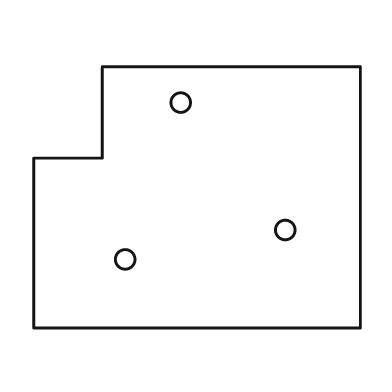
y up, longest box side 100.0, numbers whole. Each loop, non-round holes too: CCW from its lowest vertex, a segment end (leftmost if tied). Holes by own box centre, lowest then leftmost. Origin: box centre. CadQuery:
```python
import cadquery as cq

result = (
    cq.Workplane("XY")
    .moveTo(-50.0, -40.0)
    .lineTo(50.0, -40.0)
    .lineTo(50.0, 40.0)
    .lineTo(-29.0, 40.0)
    .lineTo(-29.0, 12.0)
    .lineTo(-50.0, 12.0)
    .close()
    .moveTo(-22.0, -19.0)
    .circle(3.0)
    .moveTo(27.0, -10.0)
    .circle(3.0)
    .moveTo(-5.0, 29.0)
    .circle(3.0)
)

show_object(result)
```